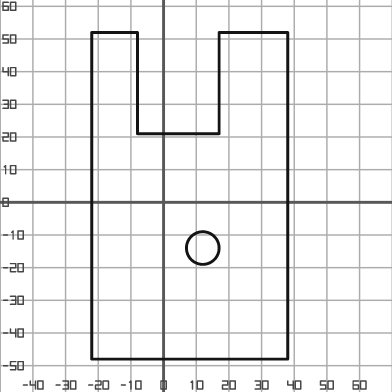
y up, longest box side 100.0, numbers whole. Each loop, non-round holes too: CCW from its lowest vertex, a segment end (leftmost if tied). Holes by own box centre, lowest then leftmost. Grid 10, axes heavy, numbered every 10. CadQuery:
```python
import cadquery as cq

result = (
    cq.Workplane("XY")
    .moveTo(-22.0, -48.0)
    .lineTo(38.0, -48.0)
    .lineTo(38.0, 52.0)
    .lineTo(17.0, 52.0)
    .lineTo(17.0, 21.0)
    .lineTo(-8.0, 21.0)
    .lineTo(-8.0, 52.0)
    .lineTo(-22.0, 52.0)
    .close()
    .moveTo(12.0, -14.0)
    .circle(5.0)
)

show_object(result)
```